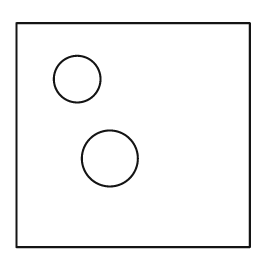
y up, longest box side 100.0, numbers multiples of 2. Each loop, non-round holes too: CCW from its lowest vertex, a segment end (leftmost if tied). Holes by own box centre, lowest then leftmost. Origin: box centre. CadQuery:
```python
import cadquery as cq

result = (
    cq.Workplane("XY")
    .moveTo(-50.0, -48.0)
    .lineTo(50.0, -48.0)
    .lineTo(50.0, 48.0)
    .lineTo(-50.0, 48.0)
    .close()
    .moveTo(-10.0, -10.0)
    .circle(12.0)
    .moveTo(-24.0, 24.0)
    .circle(10.0)
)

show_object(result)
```